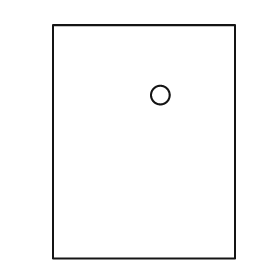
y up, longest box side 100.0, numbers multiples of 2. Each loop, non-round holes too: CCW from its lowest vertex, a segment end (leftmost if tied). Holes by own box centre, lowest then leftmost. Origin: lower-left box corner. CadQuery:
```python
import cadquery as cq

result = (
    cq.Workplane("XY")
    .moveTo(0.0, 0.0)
    .lineTo(78.0, 0.0)
    .lineTo(78.0, 100.0)
    .lineTo(0.0, 100.0)
    .close()
    .moveTo(46.0, 70.0)
    .circle(4.0)
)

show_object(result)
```